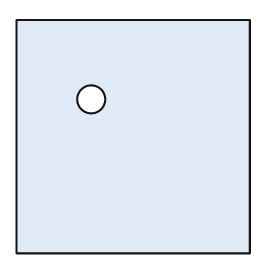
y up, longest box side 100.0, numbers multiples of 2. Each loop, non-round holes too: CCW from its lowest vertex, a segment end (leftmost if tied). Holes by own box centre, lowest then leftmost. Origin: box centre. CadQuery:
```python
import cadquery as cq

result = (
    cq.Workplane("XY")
    .moveTo(-50.0, -50.0)
    .lineTo(50.0, -50.0)
    .lineTo(50.0, 50.0)
    .lineTo(-50.0, 50.0)
    .close()
    .moveTo(-18.0, 16.0)
    .circle(6.0)
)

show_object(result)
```